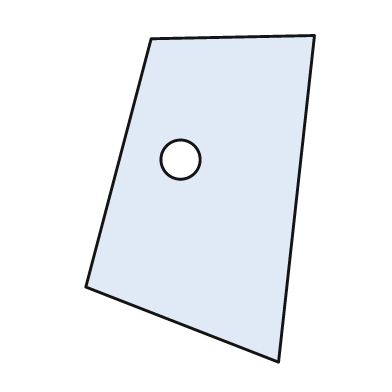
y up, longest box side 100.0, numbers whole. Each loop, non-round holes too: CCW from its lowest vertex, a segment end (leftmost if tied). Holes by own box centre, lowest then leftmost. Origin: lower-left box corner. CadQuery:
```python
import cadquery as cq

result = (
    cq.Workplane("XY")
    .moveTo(59.0, 0.0)
    .lineTo(70.0, 100.0)
    .lineTo(20.0, 99.0)
    .lineTo(0.0, 23.0)
    .close()
    .moveTo(29.0, 62.0)
    .circle(6.0)
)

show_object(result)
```